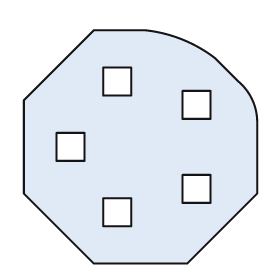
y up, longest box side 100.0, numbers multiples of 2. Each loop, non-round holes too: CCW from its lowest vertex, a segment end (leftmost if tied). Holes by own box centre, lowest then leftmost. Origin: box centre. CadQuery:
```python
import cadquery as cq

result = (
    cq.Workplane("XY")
    .moveTo(-20.0, -50.0)
    .lineTo(20.0, -50.0)
    .lineTo(50.0, -20.0)
    .lineTo(50.0, 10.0)
    .threePointArc((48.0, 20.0), (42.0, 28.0))
    .lineTo(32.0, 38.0)
    .threePointArc((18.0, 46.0), (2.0, 50.0))
    .lineTo(-20.0, 50.0)
    .lineTo(-50.0, 20.0)
    .lineTo(-50.0, -20.0)
    .close()
    .moveTo(-16.0, -34.0)
    .lineTo(-4.0, -34.0)
    .lineTo(-4.0, -22.0)
    .lineTo(-16.0, -22.0)
    .close()
    .moveTo(18.0, -24.0)
    .lineTo(30.0, -24.0)
    .lineTo(30.0, -12.0)
    .lineTo(18.0, -12.0)
    .close()
    .moveTo(-36.0, -6.0)
    .lineTo(-24.0, -6.0)
    .lineTo(-24.0, 6.0)
    .lineTo(-36.0, 6.0)
    .close()
    .moveTo(18.0, 12.0)
    .lineTo(30.0, 12.0)
    .lineTo(30.0, 24.0)
    .lineTo(18.0, 24.0)
    .close()
    .moveTo(-16.0, 22.0)
    .lineTo(-4.0, 22.0)
    .lineTo(-4.0, 34.0)
    .lineTo(-16.0, 34.0)
    .close()
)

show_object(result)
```